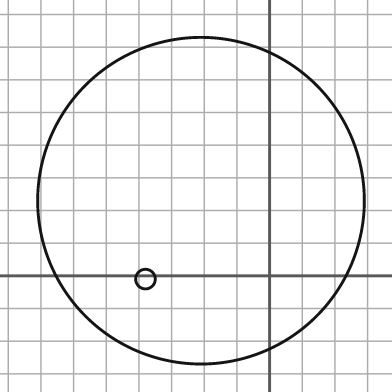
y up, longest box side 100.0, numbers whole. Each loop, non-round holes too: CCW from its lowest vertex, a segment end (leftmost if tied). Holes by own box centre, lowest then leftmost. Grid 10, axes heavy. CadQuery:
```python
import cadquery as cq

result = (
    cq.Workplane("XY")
    .moveTo(-21.0, 23.0)
    .circle(50.0)
    .moveTo(-38.0, -1.0)
    .circle(3.0)
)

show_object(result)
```